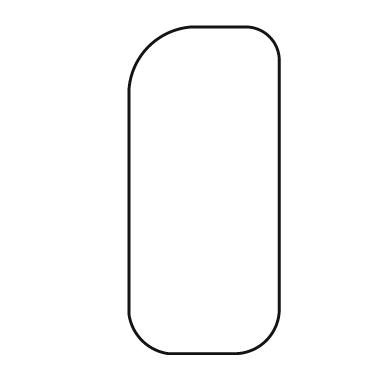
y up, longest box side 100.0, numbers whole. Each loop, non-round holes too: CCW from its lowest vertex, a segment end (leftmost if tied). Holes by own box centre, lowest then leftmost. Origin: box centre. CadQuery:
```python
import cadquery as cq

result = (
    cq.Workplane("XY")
    .moveTo(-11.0, -50.0)
    .lineTo(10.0, -50.0)
    .threePointArc((19.0, -46.0), (23.0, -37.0))
    .lineTo(23.0, 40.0)
    .threePointArc((20.0, 47.0), (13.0, 50.0))
    .lineTo(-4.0, 50.0)
    .threePointArc((-17.0, 44.0), (-23.0, 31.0))
    .lineTo(-23.0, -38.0)
    .threePointArc((-19.0, -46.0), (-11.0, -50.0))
    .close()
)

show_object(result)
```